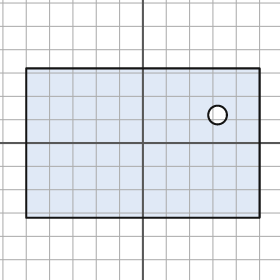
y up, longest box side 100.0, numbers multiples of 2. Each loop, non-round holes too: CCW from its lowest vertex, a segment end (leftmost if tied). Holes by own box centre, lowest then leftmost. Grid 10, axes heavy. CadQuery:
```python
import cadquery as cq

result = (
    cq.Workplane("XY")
    .moveTo(-50.0, -32.0)
    .lineTo(50.0, -32.0)
    .lineTo(50.0, 32.0)
    .lineTo(-50.0, 32.0)
    .close()
    .moveTo(32.0, 12.0)
    .circle(4.0)
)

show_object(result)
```